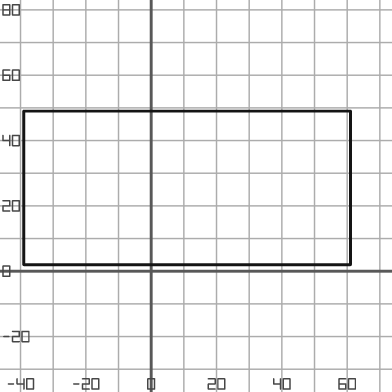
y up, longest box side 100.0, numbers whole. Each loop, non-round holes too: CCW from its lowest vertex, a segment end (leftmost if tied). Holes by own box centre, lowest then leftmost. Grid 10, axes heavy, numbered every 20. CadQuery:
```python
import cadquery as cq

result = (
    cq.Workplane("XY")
    .moveTo(-39.0, 2.0)
    .lineTo(61.0, 2.0)
    .lineTo(61.0, 49.0)
    .lineTo(-39.0, 49.0)
    .close()
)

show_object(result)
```